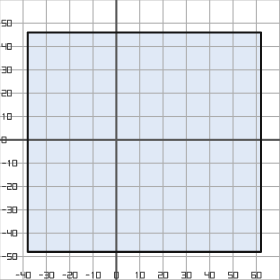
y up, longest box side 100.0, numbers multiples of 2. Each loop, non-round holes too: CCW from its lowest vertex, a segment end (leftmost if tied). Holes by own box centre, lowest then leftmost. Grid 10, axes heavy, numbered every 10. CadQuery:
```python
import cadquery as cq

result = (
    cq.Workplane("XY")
    .moveTo(-38.0, -48.0)
    .lineTo(62.0, -48.0)
    .lineTo(62.0, 46.0)
    .lineTo(-38.0, 46.0)
    .close()
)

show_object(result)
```